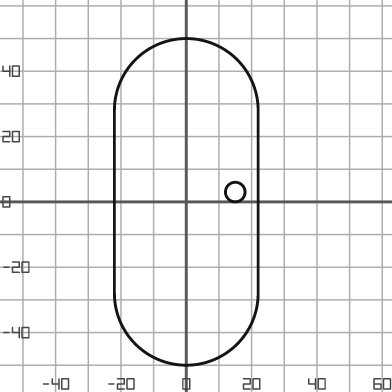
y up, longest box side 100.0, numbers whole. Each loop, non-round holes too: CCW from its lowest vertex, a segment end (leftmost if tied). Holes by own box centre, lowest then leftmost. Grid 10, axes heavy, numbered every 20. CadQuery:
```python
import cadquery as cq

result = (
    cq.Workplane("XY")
    .moveTo(-22.0, -28.0)
    .threePointArc((0.0, -50.0), (22.0, -28.0))
    .lineTo(22.0, 28.0)
    .threePointArc((0.0, 50.0), (-22.0, 28.0))
    .close()
    .moveTo(15.0, 3.0)
    .circle(3.0)
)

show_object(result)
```